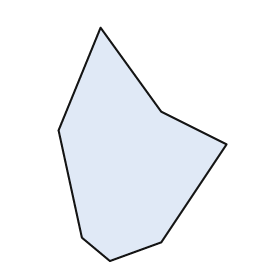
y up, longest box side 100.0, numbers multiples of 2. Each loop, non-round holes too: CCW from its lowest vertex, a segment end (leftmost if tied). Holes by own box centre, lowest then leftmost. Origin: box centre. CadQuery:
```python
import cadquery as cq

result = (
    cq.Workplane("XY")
    .moveTo(-14.0, -50.0)
    .lineTo(8.0, -42.0)
    .lineTo(36.0, 0.0)
    .lineTo(8.0, 14.0)
    .lineTo(-18.0, 50.0)
    .lineTo(-36.0, 6.0)
    .lineTo(-26.0, -40.0)
    .close()
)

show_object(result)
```